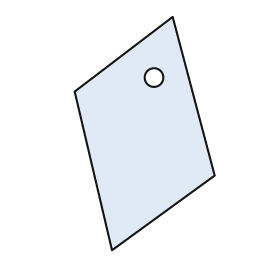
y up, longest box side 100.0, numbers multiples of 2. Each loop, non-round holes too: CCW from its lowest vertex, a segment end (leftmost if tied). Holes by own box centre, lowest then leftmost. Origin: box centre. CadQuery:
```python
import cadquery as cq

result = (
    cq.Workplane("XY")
    .moveTo(-14.0, -50.0)
    .lineTo(30.0, -18.0)
    .lineTo(12.0, 50.0)
    .lineTo(-30.0, 18.0)
    .close()
    .moveTo(4.0, 24.0)
    .circle(4.0)
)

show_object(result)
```